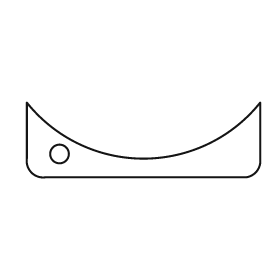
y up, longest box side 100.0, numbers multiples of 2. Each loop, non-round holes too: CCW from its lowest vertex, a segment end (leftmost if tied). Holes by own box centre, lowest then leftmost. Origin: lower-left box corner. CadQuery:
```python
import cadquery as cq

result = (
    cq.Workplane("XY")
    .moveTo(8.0, 0.0)
    .lineTo(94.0, 0.0)
    .threePointArc((98.0, 2.0), (100.0, 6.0))
    .lineTo(100.0, 32.0)
    .threePointArc((50.0, 8.0), (0.0, 32.0))
    .lineTo(0.0, 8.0)
    .threePointArc((2.0, 2.0), (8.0, 0.0))
    .close()
    .moveTo(14.0, 10.0)
    .circle(4.0)
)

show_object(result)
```